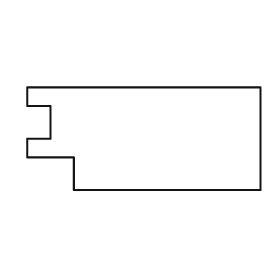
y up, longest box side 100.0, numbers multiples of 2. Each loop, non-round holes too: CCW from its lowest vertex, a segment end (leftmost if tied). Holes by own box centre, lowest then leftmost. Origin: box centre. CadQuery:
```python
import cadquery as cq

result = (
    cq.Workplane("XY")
    .moveTo(-30.0, -22.0)
    .lineTo(50.0, -22.0)
    .lineTo(50.0, 22.0)
    .lineTo(-50.0, 22.0)
    .lineTo(-50.0, 14.0)
    .lineTo(-40.0, 14.0)
    .lineTo(-40.0, 0.0)
    .lineTo(-50.0, 0.0)
    .lineTo(-50.0, -8.0)
    .lineTo(-30.0, -8.0)
    .close()
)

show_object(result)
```